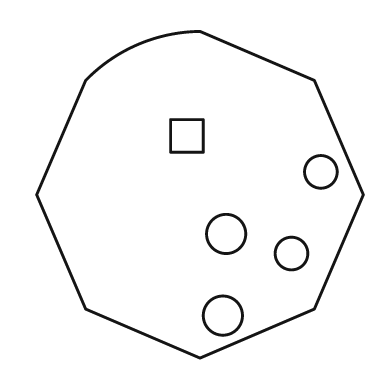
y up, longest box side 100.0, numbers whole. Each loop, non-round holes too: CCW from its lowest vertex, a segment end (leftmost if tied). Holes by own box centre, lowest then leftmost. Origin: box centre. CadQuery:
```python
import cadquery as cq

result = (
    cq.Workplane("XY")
    .moveTo(0.0, -50.0)
    .lineTo(35.0, -35.0)
    .lineTo(50.0, 0.0)
    .lineTo(35.0, 35.0)
    .lineTo(0.0, 50.0)
    .threePointArc((-19.0, 46.0), (-35.0, 35.0))
    .lineTo(-50.0, 0.0)
    .lineTo(-35.0, -35.0)
    .close()
    .moveTo(7.0, -37.0)
    .circle(6.0)
    .moveTo(28.0, -18.0)
    .circle(5.0)
    .moveTo(8.0, -12.0)
    .circle(6.0)
    .moveTo(37.0, 7.0)
    .circle(5.0)
    .moveTo(-9.0, 13.0)
    .lineTo(1.0, 13.0)
    .lineTo(1.0, 23.0)
    .lineTo(-9.0, 23.0)
    .close()
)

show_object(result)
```